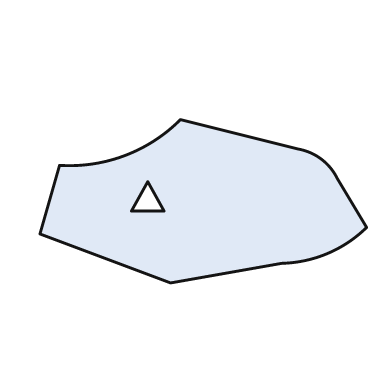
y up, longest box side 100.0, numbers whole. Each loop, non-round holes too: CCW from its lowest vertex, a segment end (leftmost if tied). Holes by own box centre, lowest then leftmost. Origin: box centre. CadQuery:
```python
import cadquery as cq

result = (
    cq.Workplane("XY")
    .moveTo(-10.0, -25.0)
    .lineTo(24.0, -19.0)
    .threePointArc((38.0, -16.0), (50.0, -8.0))
    .lineTo(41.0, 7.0)
    .threePointArc((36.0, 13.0), (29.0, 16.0))
    .lineTo(-7.0, 25.0)
    .threePointArc((-24.0, 14.0), (-44.0, 11.0))
    .lineTo(-50.0, -10.0)
    .close()
    .moveTo(-22.0, -3.0)
    .lineTo(-12.0, -3.0)
    .lineTo(-17.0, 6.0)
    .close()
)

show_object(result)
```